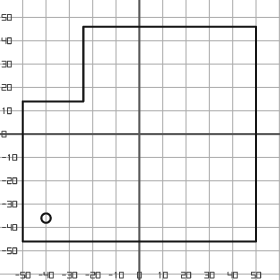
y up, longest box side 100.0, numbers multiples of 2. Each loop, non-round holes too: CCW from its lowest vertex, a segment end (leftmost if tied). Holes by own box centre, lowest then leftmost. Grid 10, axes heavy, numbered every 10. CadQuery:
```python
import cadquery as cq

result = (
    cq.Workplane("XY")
    .moveTo(-50.0, -46.0)
    .lineTo(50.0, -46.0)
    .lineTo(50.0, 46.0)
    .lineTo(-24.0, 46.0)
    .lineTo(-24.0, 14.0)
    .lineTo(-50.0, 14.0)
    .close()
    .moveTo(-40.0, -36.0)
    .circle(2.0)
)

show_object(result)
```